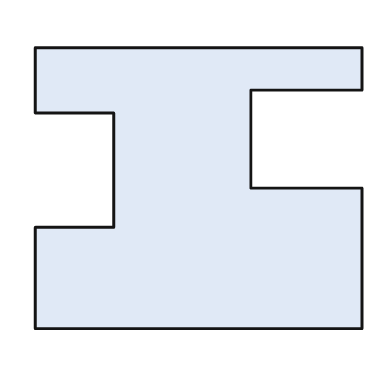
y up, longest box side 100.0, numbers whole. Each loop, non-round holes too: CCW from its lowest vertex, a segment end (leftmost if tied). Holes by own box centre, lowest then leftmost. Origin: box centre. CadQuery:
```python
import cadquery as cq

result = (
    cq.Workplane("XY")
    .moveTo(-50.0, -43.0)
    .lineTo(50.0, -43.0)
    .lineTo(50.0, 0.0)
    .lineTo(16.0, 0.0)
    .lineTo(16.0, 30.0)
    .lineTo(50.0, 30.0)
    .lineTo(50.0, 43.0)
    .lineTo(-50.0, 43.0)
    .lineTo(-50.0, 23.0)
    .lineTo(-26.0, 23.0)
    .lineTo(-26.0, -12.0)
    .lineTo(-50.0, -12.0)
    .close()
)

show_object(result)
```